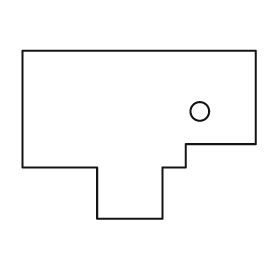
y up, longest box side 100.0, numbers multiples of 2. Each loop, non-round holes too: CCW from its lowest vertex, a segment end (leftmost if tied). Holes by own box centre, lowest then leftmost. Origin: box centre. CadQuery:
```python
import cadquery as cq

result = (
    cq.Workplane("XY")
    .moveTo(-18.0, -36.0)
    .lineTo(10.0, -36.0)
    .lineTo(10.0, -14.0)
    .lineTo(20.0, -14.0)
    .lineTo(20.0, -4.0)
    .lineTo(50.0, -4.0)
    .lineTo(50.0, 36.0)
    .lineTo(-50.0, 36.0)
    .lineTo(-50.0, -14.0)
    .lineTo(-18.0, -14.0)
    .close()
    .moveTo(26.0, 10.0)
    .circle(4.0)
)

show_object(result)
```